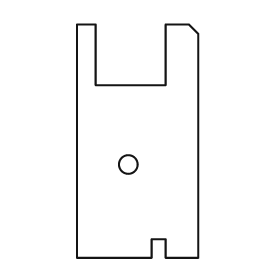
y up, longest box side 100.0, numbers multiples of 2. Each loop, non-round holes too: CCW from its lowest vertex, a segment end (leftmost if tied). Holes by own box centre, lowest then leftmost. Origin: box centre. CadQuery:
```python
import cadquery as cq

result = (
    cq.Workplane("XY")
    .moveTo(-26.0, -50.0)
    .lineTo(6.0, -50.0)
    .lineTo(6.0, -42.0)
    .lineTo(12.0, -42.0)
    .lineTo(12.0, -50.0)
    .lineTo(26.0, -50.0)
    .lineTo(26.0, 46.0)
    .lineTo(22.0, 50.0)
    .lineTo(12.0, 50.0)
    .lineTo(12.0, 24.0)
    .lineTo(-18.0, 24.0)
    .lineTo(-18.0, 50.0)
    .lineTo(-26.0, 50.0)
    .close()
    .moveTo(-4.0, -10.0)
    .circle(4.0)
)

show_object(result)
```